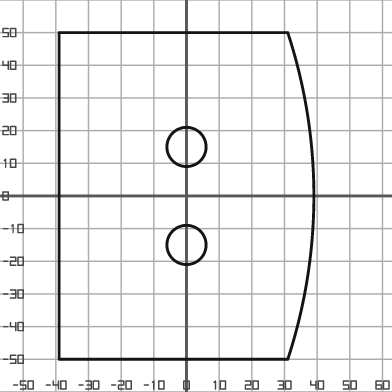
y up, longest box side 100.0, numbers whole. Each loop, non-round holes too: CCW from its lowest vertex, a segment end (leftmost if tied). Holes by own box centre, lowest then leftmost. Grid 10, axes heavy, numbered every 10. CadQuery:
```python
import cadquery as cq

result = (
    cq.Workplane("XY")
    .moveTo(-39.0, -50.0)
    .lineTo(31.0, -50.0)
    .threePointArc((39.0, 0.0), (31.0, 50.0))
    .lineTo(-39.0, 50.0)
    .close()
    .moveTo(0.0, -15.0)
    .circle(6.0)
    .moveTo(0.0, 15.0)
    .circle(6.0)
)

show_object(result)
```